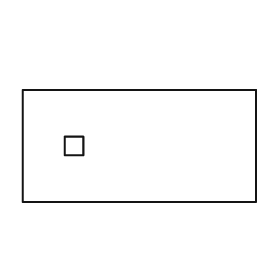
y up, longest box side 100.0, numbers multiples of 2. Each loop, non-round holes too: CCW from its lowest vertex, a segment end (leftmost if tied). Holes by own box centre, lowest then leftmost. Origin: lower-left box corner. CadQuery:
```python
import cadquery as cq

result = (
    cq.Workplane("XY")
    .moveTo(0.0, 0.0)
    .lineTo(100.0, 0.0)
    .lineTo(100.0, 48.0)
    .lineTo(0.0, 48.0)
    .close()
    .moveTo(18.0, 20.0)
    .lineTo(26.0, 20.0)
    .lineTo(26.0, 28.0)
    .lineTo(18.0, 28.0)
    .close()
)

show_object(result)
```